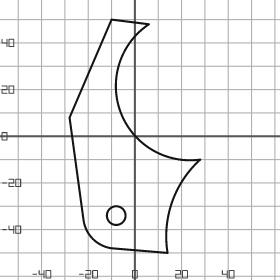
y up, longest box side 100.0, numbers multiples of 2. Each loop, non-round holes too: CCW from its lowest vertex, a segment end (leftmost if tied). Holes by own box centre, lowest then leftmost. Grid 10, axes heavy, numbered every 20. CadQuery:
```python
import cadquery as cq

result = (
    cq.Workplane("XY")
    .moveTo(14.0, -50.0)
    .threePointArc((16.0, -28.0), (28.0, -10.0))
    .threePointArc((-6.0, 10.0), (6.0, 48.0))
    .lineTo(-10.0, 50.0)
    .lineTo(-28.0, 8.0)
    .lineTo(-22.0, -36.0)
    .threePointArc((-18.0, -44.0), (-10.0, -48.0))
    .close()
    .moveTo(-8.0, -34.0)
    .circle(4.0)
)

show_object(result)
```